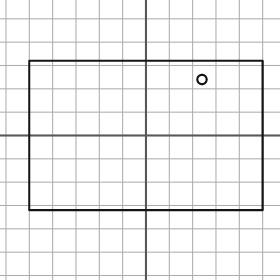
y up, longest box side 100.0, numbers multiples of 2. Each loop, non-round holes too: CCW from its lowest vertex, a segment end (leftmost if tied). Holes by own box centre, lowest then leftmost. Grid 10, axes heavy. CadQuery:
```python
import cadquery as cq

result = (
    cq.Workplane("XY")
    .moveTo(-50.0, -32.0)
    .lineTo(50.0, -32.0)
    .lineTo(50.0, 32.0)
    .lineTo(-50.0, 32.0)
    .close()
    .moveTo(24.0, 24.0)
    .circle(2.0)
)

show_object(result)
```